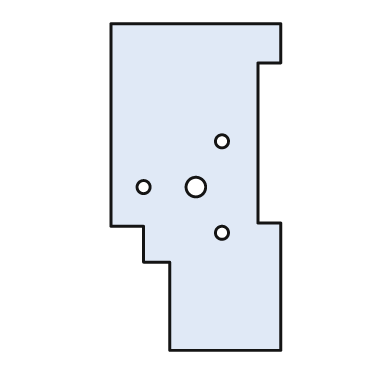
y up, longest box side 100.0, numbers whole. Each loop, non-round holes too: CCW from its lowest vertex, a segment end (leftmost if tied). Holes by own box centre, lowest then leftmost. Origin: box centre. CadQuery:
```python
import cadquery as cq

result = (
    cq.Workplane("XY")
    .moveTo(-8.0, -50.0)
    .lineTo(26.0, -50.0)
    .lineTo(26.0, -11.0)
    .lineTo(19.0, -11.0)
    .lineTo(19.0, 38.0)
    .lineTo(26.0, 38.0)
    .lineTo(26.0, 50.0)
    .lineTo(-26.0, 50.0)
    .lineTo(-26.0, -12.0)
    .lineTo(-16.0, -12.0)
    .lineTo(-16.0, -23.0)
    .lineTo(-8.0, -23.0)
    .close()
    .moveTo(8.0, -14.0)
    .circle(2.0)
    .moveTo(-16.0, 0.0)
    .circle(2.0)
    .moveTo(0.0, 0.0)
    .circle(3.0)
    .moveTo(8.0, 14.0)
    .circle(2.0)
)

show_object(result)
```